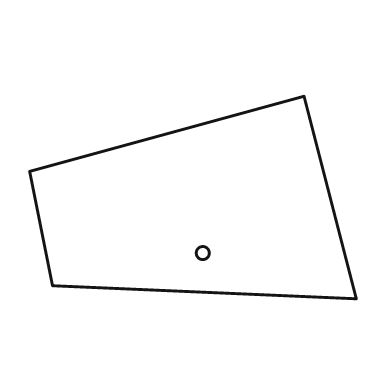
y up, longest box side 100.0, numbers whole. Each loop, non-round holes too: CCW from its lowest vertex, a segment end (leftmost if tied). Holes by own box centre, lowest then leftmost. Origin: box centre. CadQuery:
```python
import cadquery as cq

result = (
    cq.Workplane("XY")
    .moveTo(50.0, -31.0)
    .lineTo(34.0, 31.0)
    .lineTo(-50.0, 8.0)
    .lineTo(-43.0, -27.0)
    .close()
    .moveTo(3.0, -17.0)
    .circle(2.0)
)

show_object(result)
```